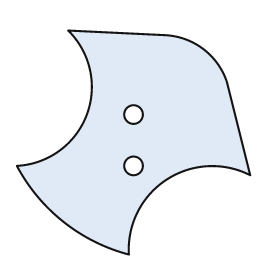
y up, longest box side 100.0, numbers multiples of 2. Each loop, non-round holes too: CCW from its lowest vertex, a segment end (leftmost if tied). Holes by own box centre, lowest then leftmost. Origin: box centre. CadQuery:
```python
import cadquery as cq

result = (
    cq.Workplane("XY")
    .moveTo(-2.0, -48.0)
    .threePointArc((14.0, -16.0), (50.0, -14.0))
    .lineTo(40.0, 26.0)
    .threePointArc((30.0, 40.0), (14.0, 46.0))
    .lineTo(-28.0, 48.0)
    .threePointArc((-20.0, 12.0), (-50.0, -10.0))
    .threePointArc((-30.0, -34.0), (-2.0, -48.0))
    .close()
    .moveTo(0.0, -10.0)
    .circle(4.0)
    .moveTo(0.0, 12.0)
    .circle(4.0)
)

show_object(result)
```